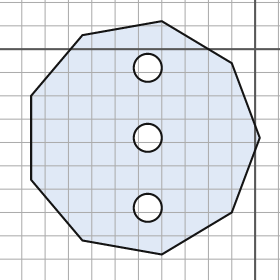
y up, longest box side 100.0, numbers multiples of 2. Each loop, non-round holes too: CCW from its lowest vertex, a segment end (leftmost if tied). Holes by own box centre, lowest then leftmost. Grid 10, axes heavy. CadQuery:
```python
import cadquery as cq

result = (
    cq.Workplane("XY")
    .moveTo(-40.0, -88.0)
    .lineTo(-10.0, -70.0)
    .lineTo(2.0, -38.0)
    .lineTo(-10.0, -6.0)
    .lineTo(-40.0, 12.0)
    .lineTo(-74.0, 6.0)
    .lineTo(-96.0, -20.0)
    .lineTo(-96.0, -56.0)
    .lineTo(-74.0, -82.0)
    .close()
    .moveTo(-46.0, -68.0)
    .circle(6.0)
    .moveTo(-46.0, -38.0)
    .circle(6.0)
    .moveTo(-46.0, -8.0)
    .circle(6.0)
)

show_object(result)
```